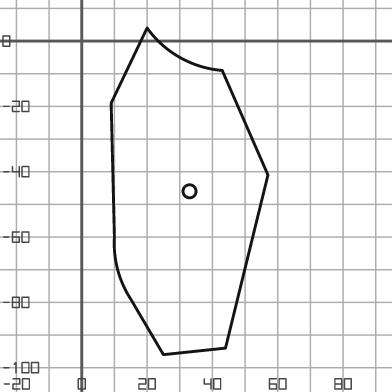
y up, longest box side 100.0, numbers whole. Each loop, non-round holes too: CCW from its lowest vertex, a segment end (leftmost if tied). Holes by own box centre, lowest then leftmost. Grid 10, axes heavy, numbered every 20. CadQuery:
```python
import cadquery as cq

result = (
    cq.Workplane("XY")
    .moveTo(25.0, -96.0)
    .lineTo(44.0, -94.0)
    .lineTo(57.0, -41.0)
    .lineTo(43.0, -9.0)
    .threePointArc((30.0, -5.0), (20.0, 4.0))
    .lineTo(9.0, -19.0)
    .lineTo(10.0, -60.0)
    .threePointArc((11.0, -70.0), (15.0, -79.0))
    .close()
    .moveTo(33.0, -46.0)
    .circle(2.0)
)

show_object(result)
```